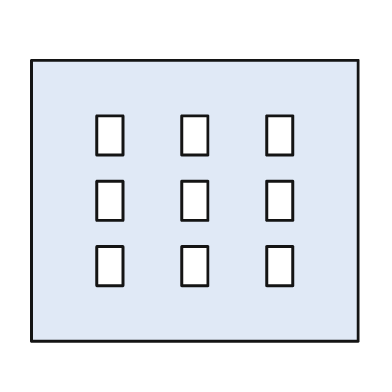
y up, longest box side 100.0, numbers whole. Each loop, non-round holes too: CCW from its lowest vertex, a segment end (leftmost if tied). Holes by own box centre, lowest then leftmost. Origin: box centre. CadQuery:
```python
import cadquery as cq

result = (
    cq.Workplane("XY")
    .moveTo(-50.0, -43.0)
    .lineTo(50.0, -43.0)
    .lineTo(50.0, 43.0)
    .lineTo(-50.0, 43.0)
    .close()
    .moveTo(-30.0, -26.0)
    .lineTo(-22.0, -26.0)
    .lineTo(-22.0, -14.0)
    .lineTo(-30.0, -14.0)
    .close()
    .moveTo(-4.0, -26.0)
    .lineTo(4.0, -26.0)
    .lineTo(4.0, -14.0)
    .lineTo(-4.0, -14.0)
    .close()
    .moveTo(22.0, -26.0)
    .lineTo(30.0, -26.0)
    .lineTo(30.0, -14.0)
    .lineTo(22.0, -14.0)
    .close()
    .moveTo(-30.0, -6.0)
    .lineTo(-22.0, -6.0)
    .lineTo(-22.0, 6.0)
    .lineTo(-30.0, 6.0)
    .close()
    .moveTo(-4.0, -6.0)
    .lineTo(4.0, -6.0)
    .lineTo(4.0, 6.0)
    .lineTo(-4.0, 6.0)
    .close()
    .moveTo(22.0, -6.0)
    .lineTo(30.0, -6.0)
    .lineTo(30.0, 6.0)
    .lineTo(22.0, 6.0)
    .close()
    .moveTo(-30.0, 14.0)
    .lineTo(-22.0, 14.0)
    .lineTo(-22.0, 26.0)
    .lineTo(-30.0, 26.0)
    .close()
    .moveTo(-4.0, 14.0)
    .lineTo(4.0, 14.0)
    .lineTo(4.0, 26.0)
    .lineTo(-4.0, 26.0)
    .close()
    .moveTo(22.0, 14.0)
    .lineTo(30.0, 14.0)
    .lineTo(30.0, 26.0)
    .lineTo(22.0, 26.0)
    .close()
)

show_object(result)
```